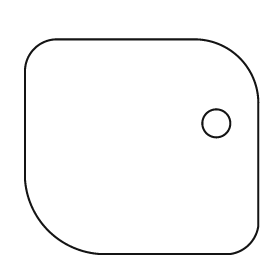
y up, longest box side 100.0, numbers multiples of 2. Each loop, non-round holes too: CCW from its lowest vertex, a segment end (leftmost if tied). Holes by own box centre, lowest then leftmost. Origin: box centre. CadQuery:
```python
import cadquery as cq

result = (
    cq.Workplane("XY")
    .moveTo(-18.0, -46.0)
    .lineTo(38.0, -46.0)
    .threePointArc((46.0, -42.0), (50.0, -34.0))
    .lineTo(50.0, 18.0)
    .threePointArc((42.0, 38.0), (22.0, 46.0))
    .lineTo(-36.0, 46.0)
    .threePointArc((-46.0, 42.0), (-50.0, 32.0))
    .lineTo(-50.0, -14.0)
    .threePointArc((-40.0, -36.0), (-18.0, -46.0))
    .close()
    .moveTo(32.0, 10.0)
    .circle(6.0)
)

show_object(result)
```